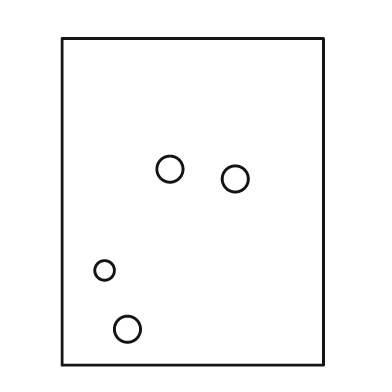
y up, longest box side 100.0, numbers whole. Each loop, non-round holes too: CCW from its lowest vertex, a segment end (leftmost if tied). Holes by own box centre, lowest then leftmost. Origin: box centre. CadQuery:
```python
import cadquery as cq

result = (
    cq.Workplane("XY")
    .moveTo(-40.0, -50.0)
    .lineTo(40.0, -50.0)
    .lineTo(40.0, 50.0)
    .lineTo(-40.0, 50.0)
    .close()
    .moveTo(-20.0, -39.0)
    .circle(4.0)
    .moveTo(-27.0, -21.0)
    .circle(3.0)
    .moveTo(13.0, 7.0)
    .circle(4.0)
    .moveTo(-7.0, 10.0)
    .circle(4.0)
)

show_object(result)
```